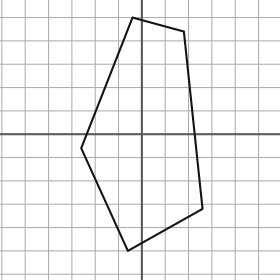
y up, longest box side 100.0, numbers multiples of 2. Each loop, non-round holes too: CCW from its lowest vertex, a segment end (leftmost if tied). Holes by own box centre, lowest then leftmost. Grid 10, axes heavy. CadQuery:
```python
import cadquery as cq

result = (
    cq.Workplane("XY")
    .moveTo(-6.0, -50.0)
    .lineTo(26.0, -32.0)
    .lineTo(18.0, 44.0)
    .lineTo(-4.0, 50.0)
    .lineTo(-26.0, -6.0)
    .close()
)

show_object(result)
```